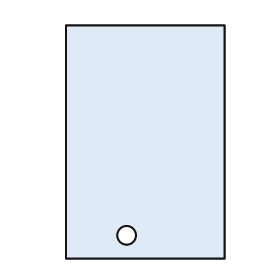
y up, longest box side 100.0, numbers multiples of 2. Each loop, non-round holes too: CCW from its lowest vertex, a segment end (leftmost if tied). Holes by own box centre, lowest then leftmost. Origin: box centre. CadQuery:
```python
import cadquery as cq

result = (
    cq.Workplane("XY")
    .moveTo(-34.0, -50.0)
    .lineTo(34.0, -50.0)
    .lineTo(34.0, 50.0)
    .lineTo(-34.0, 50.0)
    .close()
    .moveTo(-8.0, -40.0)
    .circle(4.0)
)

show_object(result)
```